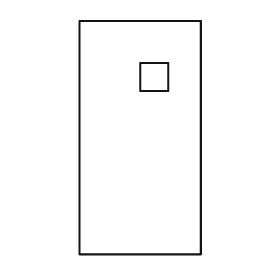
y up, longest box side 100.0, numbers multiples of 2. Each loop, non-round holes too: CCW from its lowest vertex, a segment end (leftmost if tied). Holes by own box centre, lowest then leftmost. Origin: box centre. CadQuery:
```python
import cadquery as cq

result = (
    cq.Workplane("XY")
    .moveTo(-26.0, -50.0)
    .lineTo(26.0, -50.0)
    .lineTo(26.0, 50.0)
    .lineTo(-26.0, 50.0)
    .close()
    .moveTo(0.0, 20.0)
    .lineTo(12.0, 20.0)
    .lineTo(12.0, 32.0)
    .lineTo(0.0, 32.0)
    .close()
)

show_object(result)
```